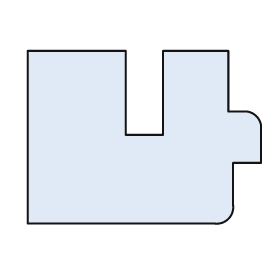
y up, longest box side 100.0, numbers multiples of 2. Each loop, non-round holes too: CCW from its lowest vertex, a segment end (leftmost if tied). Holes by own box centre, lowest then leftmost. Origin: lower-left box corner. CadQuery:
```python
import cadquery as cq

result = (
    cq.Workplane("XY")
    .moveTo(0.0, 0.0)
    .lineTo(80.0, 0.0)
    .threePointArc((86.0, 2.0), (88.0, 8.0))
    .lineTo(88.0, 26.0)
    .lineTo(100.0, 26.0)
    .lineTo(100.0, 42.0)
    .threePointArc((98.0, 46.0), (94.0, 48.0))
    .lineTo(86.0, 48.0)
    .lineTo(86.0, 74.0)
    .lineTo(58.0, 74.0)
    .lineTo(58.0, 38.0)
    .lineTo(42.0, 38.0)
    .lineTo(42.0, 74.0)
    .lineTo(0.0, 74.0)
    .close()
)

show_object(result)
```